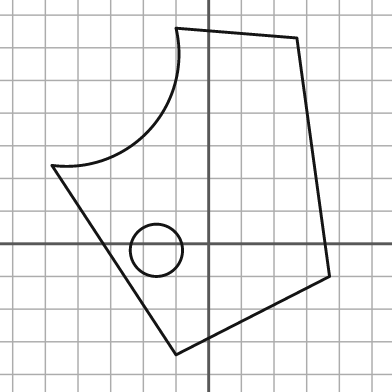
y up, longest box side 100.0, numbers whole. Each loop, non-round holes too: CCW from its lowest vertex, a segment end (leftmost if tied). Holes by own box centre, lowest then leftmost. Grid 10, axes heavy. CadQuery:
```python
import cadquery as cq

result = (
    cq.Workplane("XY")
    .moveTo(-10.0, -34.0)
    .lineTo(37.0, -10.0)
    .lineTo(27.0, 63.0)
    .lineTo(-10.0, 66.0)
    .threePointArc((-18.0, 35.0), (-48.0, 24.0))
    .close()
    .moveTo(-16.0, -2.0)
    .circle(8.0)
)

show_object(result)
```